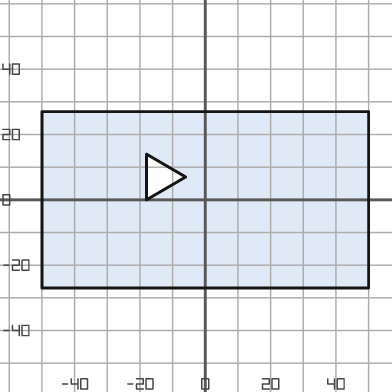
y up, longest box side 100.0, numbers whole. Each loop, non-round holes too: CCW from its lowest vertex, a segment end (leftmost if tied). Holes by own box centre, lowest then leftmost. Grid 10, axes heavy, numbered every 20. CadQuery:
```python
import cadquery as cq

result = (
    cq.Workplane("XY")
    .moveTo(-50.0, -27.0)
    .lineTo(50.0, -27.0)
    .lineTo(50.0, 27.0)
    .lineTo(-50.0, 27.0)
    .close()
    .moveTo(-18.0, 0.0)
    .lineTo(-6.0, 7.0)
    .lineTo(-18.0, 14.0)
    .close()
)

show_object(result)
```